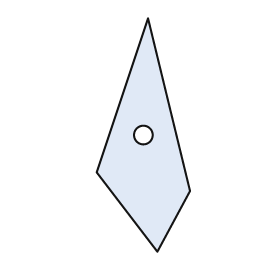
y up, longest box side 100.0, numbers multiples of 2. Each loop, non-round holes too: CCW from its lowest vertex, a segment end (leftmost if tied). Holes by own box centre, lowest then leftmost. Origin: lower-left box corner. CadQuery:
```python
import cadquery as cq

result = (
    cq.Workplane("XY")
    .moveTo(26.0, 0.0)
    .lineTo(40.0, 26.0)
    .lineTo(22.0, 100.0)
    .lineTo(0.0, 34.0)
    .close()
    .moveTo(20.0, 50.0)
    .circle(4.0)
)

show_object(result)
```